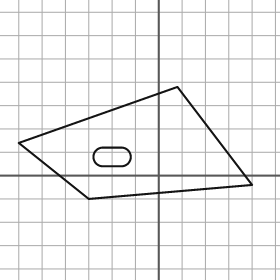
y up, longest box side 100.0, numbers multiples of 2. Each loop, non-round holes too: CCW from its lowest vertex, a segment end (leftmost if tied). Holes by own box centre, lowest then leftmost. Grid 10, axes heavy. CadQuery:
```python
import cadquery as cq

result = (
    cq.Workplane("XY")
    .moveTo(-30.0, -10.0)
    .lineTo(40.0, -4.0)
    .lineTo(8.0, 38.0)
    .lineTo(-60.0, 14.0)
    .close()
    .moveTo(-24.0, 4.0)
    .lineTo(-16.0, 4.0)
    .threePointArc((-12.0, 8.0), (-16.0, 12.0))
    .lineTo(-24.0, 12.0)
    .threePointArc((-28.0, 8.0), (-24.0, 4.0))
    .close()
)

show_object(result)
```